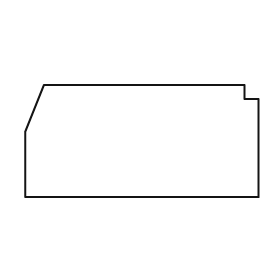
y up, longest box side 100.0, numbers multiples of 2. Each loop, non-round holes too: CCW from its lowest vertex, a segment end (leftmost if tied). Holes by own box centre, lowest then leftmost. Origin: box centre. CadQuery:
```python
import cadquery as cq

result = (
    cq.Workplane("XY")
    .moveTo(-50.0, -24.0)
    .lineTo(50.0, -24.0)
    .lineTo(50.0, 18.0)
    .lineTo(44.0, 18.0)
    .lineTo(44.0, 24.0)
    .lineTo(-42.0, 24.0)
    .lineTo(-50.0, 4.0)
    .close()
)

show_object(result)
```